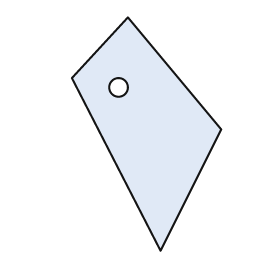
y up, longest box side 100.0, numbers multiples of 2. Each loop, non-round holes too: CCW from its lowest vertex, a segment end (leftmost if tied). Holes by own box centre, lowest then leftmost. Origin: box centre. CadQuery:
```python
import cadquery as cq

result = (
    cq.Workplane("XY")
    .moveTo(6.0, -50.0)
    .lineTo(32.0, 2.0)
    .lineTo(-8.0, 50.0)
    .lineTo(-32.0, 24.0)
    .close()
    .moveTo(-12.0, 20.0)
    .circle(4.0)
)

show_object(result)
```